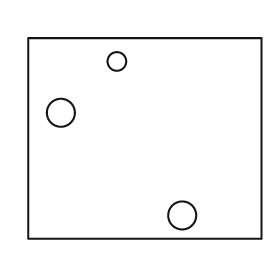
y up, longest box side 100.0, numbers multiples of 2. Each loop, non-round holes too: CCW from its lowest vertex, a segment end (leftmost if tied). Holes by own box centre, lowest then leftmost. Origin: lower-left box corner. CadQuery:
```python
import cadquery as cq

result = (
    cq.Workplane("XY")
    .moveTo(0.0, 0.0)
    .lineTo(100.0, 0.0)
    .lineTo(100.0, 86.0)
    .lineTo(0.0, 86.0)
    .close()
    .moveTo(66.0, 10.0)
    .circle(6.0)
    .moveTo(14.0, 54.0)
    .circle(6.0)
    .moveTo(38.0, 76.0)
    .circle(4.0)
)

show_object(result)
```